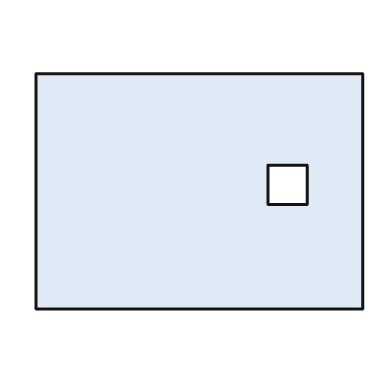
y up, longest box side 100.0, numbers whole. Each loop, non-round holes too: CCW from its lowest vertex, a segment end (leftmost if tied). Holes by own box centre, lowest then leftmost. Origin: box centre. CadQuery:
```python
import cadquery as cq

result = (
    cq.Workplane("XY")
    .moveTo(-50.0, -36.0)
    .lineTo(50.0, -36.0)
    .lineTo(50.0, 36.0)
    .lineTo(-50.0, 36.0)
    .close()
    .moveTo(21.0, -4.0)
    .lineTo(33.0, -4.0)
    .lineTo(33.0, 8.0)
    .lineTo(21.0, 8.0)
    .close()
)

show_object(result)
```